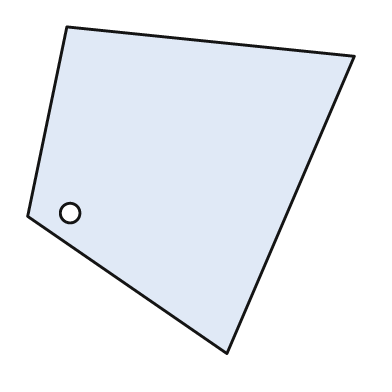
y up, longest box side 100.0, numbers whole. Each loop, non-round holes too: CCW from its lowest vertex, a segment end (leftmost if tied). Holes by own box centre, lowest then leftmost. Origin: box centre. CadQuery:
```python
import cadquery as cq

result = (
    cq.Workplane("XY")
    .moveTo(11.0, -50.0)
    .lineTo(50.0, 41.0)
    .lineTo(-38.0, 50.0)
    .lineTo(-50.0, -8.0)
    .close()
    .moveTo(-37.0, -7.0)
    .circle(3.0)
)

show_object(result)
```